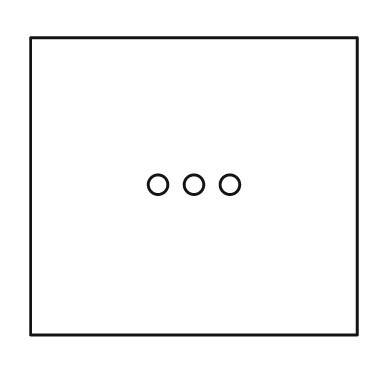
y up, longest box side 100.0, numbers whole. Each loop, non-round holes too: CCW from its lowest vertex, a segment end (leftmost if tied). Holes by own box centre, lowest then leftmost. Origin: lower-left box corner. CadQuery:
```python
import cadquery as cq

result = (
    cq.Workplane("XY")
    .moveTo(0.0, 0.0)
    .lineTo(100.0, 0.0)
    .lineTo(100.0, 91.0)
    .lineTo(0.0, 91.0)
    .close()
    .moveTo(39.0, 46.0)
    .circle(3.0)
    .moveTo(50.0, 46.0)
    .circle(3.0)
    .moveTo(61.0, 46.0)
    .circle(3.0)
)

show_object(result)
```